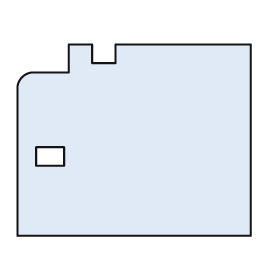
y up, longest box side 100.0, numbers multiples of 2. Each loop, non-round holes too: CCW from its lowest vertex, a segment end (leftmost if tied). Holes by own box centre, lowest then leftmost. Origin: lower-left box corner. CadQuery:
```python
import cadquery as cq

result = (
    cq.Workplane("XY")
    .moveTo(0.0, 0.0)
    .lineTo(100.0, 0.0)
    .lineTo(100.0, 82.0)
    .lineTo(42.0, 82.0)
    .lineTo(42.0, 74.0)
    .lineTo(32.0, 74.0)
    .lineTo(32.0, 82.0)
    .lineTo(22.0, 82.0)
    .lineTo(22.0, 70.0)
    .lineTo(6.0, 70.0)
    .threePointArc((2.0, 68.0), (0.0, 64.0))
    .close()
    .moveTo(8.0, 30.0)
    .lineTo(20.0, 30.0)
    .lineTo(20.0, 38.0)
    .lineTo(8.0, 38.0)
    .close()
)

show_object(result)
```